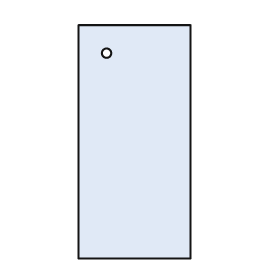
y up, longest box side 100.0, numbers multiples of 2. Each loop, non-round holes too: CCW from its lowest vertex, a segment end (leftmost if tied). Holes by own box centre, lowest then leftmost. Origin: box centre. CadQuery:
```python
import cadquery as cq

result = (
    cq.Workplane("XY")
    .moveTo(-24.0, -50.0)
    .lineTo(24.0, -50.0)
    .lineTo(24.0, 50.0)
    .lineTo(-24.0, 50.0)
    .close()
    .moveTo(-12.0, 38.0)
    .circle(2.0)
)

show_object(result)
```